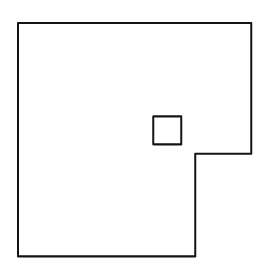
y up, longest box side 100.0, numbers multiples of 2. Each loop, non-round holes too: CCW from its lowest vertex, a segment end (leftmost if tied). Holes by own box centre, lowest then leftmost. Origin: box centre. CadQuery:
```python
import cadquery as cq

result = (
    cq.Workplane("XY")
    .moveTo(-50.0, -50.0)
    .lineTo(26.0, -50.0)
    .lineTo(26.0, -6.0)
    .lineTo(50.0, -6.0)
    .lineTo(50.0, 50.0)
    .lineTo(-50.0, 50.0)
    .close()
    .moveTo(8.0, -2.0)
    .lineTo(20.0, -2.0)
    .lineTo(20.0, 10.0)
    .lineTo(8.0, 10.0)
    .close()
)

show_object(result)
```